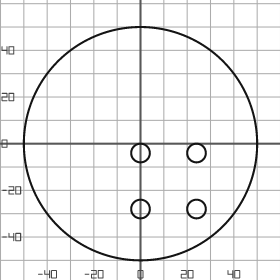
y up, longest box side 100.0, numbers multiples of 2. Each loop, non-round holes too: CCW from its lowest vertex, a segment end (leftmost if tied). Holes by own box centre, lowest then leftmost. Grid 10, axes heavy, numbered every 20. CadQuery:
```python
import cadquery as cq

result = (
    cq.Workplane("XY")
    .moveTo(0.0, 0.0)
    .circle(50.0)
    .moveTo(0.0, -28.0)
    .circle(4.0)
    .moveTo(24.0, -28.0)
    .circle(4.0)
    .moveTo(0.0, -4.0)
    .circle(4.0)
    .moveTo(24.0, -4.0)
    .circle(4.0)
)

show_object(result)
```